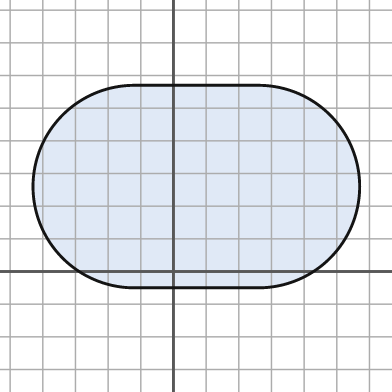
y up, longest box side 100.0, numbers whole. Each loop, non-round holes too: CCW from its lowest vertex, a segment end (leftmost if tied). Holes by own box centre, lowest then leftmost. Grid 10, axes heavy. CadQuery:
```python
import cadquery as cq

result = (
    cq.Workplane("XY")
    .moveTo(-12.0, -5.0)
    .lineTo(26.0, -5.0)
    .threePointArc((57.0, 26.0), (26.0, 57.0))
    .lineTo(-12.0, 57.0)
    .threePointArc((-43.0, 26.0), (-12.0, -5.0))
    .close()
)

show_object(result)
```